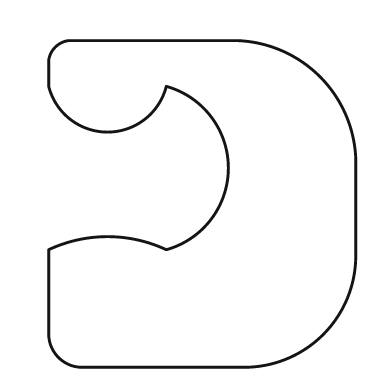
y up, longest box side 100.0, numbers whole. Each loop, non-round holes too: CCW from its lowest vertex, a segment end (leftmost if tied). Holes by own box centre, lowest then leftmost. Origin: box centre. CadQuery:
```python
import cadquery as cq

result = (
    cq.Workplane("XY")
    .moveTo(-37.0, -50.0)
    .lineTo(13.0, -50.0)
    .threePointArc((37.0, -40.0), (47.0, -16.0))
    .lineTo(47.0, 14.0)
    .threePointArc((36.0, 39.0), (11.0, 50.0))
    .lineTo(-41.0, 50.0)
    .threePointArc((-45.0, 48.0), (-47.0, 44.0))
    .lineTo(-47.0, 36.0)
    .threePointArc((-29.0, 22.0), (-11.0, 36.0))
    .threePointArc((8.0, 11.0), (-11.0, -14.0))
    .threePointArc((-29.0, -10.0), (-47.0, -14.0))
    .lineTo(-47.0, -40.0)
    .threePointArc((-44.0, -47.0), (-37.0, -50.0))
    .close()
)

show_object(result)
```